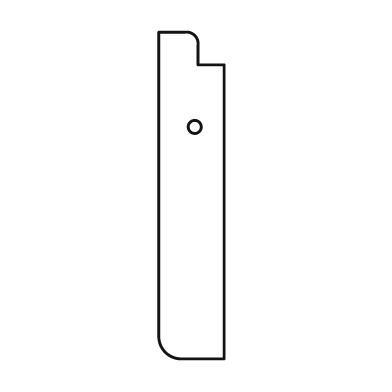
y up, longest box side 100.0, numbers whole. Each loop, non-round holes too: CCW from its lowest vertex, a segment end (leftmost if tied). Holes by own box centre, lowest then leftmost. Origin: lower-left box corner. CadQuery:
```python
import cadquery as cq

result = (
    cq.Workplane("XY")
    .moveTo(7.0, 0.0)
    .lineTo(20.0, 0.0)
    .lineTo(20.0, 90.0)
    .lineTo(12.0, 90.0)
    .lineTo(12.0, 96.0)
    .threePointArc((11.0, 99.0), (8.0, 100.0))
    .lineTo(0.0, 100.0)
    .lineTo(0.0, 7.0)
    .threePointArc((2.0, 2.0), (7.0, 0.0))
    .close()
    .moveTo(11.0, 71.0)
    .circle(2.0)
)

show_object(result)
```